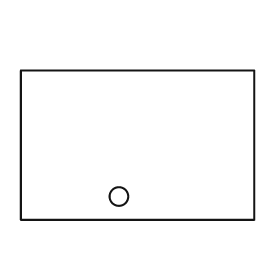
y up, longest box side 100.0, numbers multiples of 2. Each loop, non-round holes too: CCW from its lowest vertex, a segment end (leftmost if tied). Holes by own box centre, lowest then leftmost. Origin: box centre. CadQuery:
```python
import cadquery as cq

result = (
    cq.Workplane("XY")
    .moveTo(-50.0, -32.0)
    .lineTo(50.0, -32.0)
    .lineTo(50.0, 32.0)
    .lineTo(-50.0, 32.0)
    .close()
    .moveTo(-8.0, -22.0)
    .circle(4.0)
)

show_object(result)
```